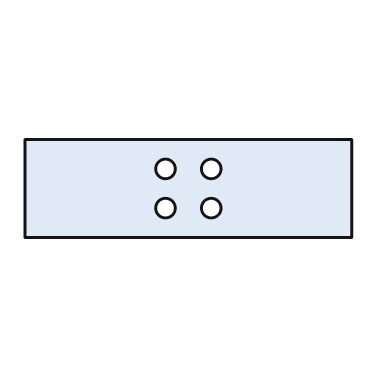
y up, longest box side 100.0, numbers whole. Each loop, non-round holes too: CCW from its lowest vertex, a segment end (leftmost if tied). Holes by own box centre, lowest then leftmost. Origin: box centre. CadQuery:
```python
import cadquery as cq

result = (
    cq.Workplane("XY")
    .moveTo(-50.0, -15.0)
    .lineTo(50.0, -15.0)
    .lineTo(50.0, 15.0)
    .lineTo(-50.0, 15.0)
    .close()
    .moveTo(-7.0, -6.0)
    .circle(3.0)
    .moveTo(7.0, -6.0)
    .circle(3.0)
    .moveTo(-7.0, 6.0)
    .circle(3.0)
    .moveTo(7.0, 6.0)
    .circle(3.0)
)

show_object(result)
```